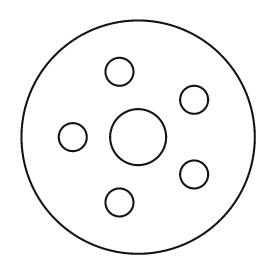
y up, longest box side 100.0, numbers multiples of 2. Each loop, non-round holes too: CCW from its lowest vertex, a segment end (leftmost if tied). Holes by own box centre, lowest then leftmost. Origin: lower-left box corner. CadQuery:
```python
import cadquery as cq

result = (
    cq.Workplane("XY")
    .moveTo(50.0, 50.0)
    .circle(50.0)
    .moveTo(42.0, 22.0)
    .circle(6.0)
    .moveTo(74.0, 34.0)
    .circle(6.0)
    .moveTo(22.0, 50.0)
    .circle(6.0)
    .moveTo(50.0, 50.0)
    .circle(12.0)
    .moveTo(74.0, 66.0)
    .circle(6.0)
    .moveTo(42.0, 78.0)
    .circle(6.0)
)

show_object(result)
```